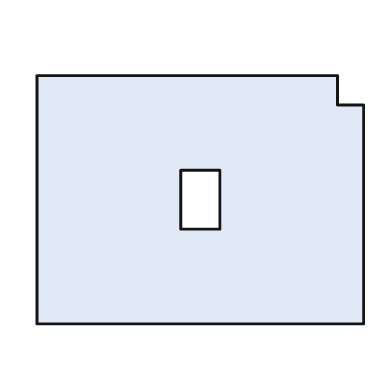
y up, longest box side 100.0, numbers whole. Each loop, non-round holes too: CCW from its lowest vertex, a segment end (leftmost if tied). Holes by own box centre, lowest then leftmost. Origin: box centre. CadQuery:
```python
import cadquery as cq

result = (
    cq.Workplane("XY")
    .moveTo(-50.0, -38.0)
    .lineTo(50.0, -38.0)
    .lineTo(50.0, 29.0)
    .lineTo(42.0, 29.0)
    .lineTo(42.0, 38.0)
    .lineTo(-50.0, 38.0)
    .close()
    .moveTo(-6.0, -9.0)
    .lineTo(6.0, -9.0)
    .lineTo(6.0, 9.0)
    .lineTo(-6.0, 9.0)
    .close()
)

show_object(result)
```